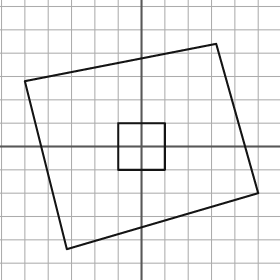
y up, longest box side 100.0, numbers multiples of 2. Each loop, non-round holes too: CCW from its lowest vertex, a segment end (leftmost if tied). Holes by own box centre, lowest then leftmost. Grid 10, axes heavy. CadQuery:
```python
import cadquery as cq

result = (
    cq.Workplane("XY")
    .moveTo(-32.0, -44.0)
    .lineTo(50.0, -20.0)
    .lineTo(32.0, 44.0)
    .lineTo(-50.0, 28.0)
    .close()
    .moveTo(-10.0, -10.0)
    .lineTo(10.0, -10.0)
    .lineTo(10.0, 10.0)
    .lineTo(-10.0, 10.0)
    .close()
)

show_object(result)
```